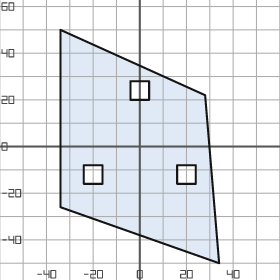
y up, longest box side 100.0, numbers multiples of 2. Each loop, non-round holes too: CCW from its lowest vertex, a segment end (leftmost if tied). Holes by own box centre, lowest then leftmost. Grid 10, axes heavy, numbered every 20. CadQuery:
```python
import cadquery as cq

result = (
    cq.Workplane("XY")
    .moveTo(34.0, -50.0)
    .lineTo(28.0, 22.0)
    .lineTo(-34.0, 50.0)
    .lineTo(-34.0, -26.0)
    .close()
    .moveTo(-24.0, -16.0)
    .lineTo(-16.0, -16.0)
    .lineTo(-16.0, -8.0)
    .lineTo(-24.0, -8.0)
    .close()
    .moveTo(16.0, -16.0)
    .lineTo(24.0, -16.0)
    .lineTo(24.0, -8.0)
    .lineTo(16.0, -8.0)
    .close()
    .moveTo(-4.0, 20.0)
    .lineTo(4.0, 20.0)
    .lineTo(4.0, 28.0)
    .lineTo(-4.0, 28.0)
    .close()
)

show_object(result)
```